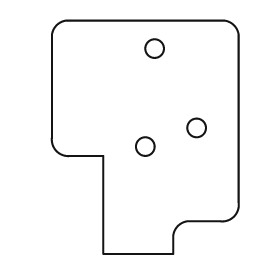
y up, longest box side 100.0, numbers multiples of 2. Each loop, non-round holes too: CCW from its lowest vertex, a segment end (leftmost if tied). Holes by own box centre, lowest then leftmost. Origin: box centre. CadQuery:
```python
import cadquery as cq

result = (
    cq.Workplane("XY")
    .moveTo(-18.0, -50.0)
    .lineTo(12.0, -50.0)
    .lineTo(12.0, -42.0)
    .threePointArc((14.0, -38.0), (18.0, -36.0))
    .lineTo(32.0, -36.0)
    .threePointArc((38.0, -34.0), (40.0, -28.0))
    .lineTo(40.0, 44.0)
    .threePointArc((38.0, 48.0), (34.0, 50.0))
    .lineTo(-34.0, 50.0)
    .threePointArc((-38.0, 48.0), (-40.0, 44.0))
    .lineTo(-40.0, 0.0)
    .threePointArc((-38.0, -6.0), (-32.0, -8.0))
    .lineTo(-18.0, -8.0)
    .close()
    .moveTo(0.0, -4.0)
    .circle(4.0)
    .moveTo(22.0, 4.0)
    .circle(4.0)
    .moveTo(4.0, 38.0)
    .circle(4.0)
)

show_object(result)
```